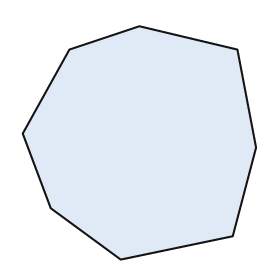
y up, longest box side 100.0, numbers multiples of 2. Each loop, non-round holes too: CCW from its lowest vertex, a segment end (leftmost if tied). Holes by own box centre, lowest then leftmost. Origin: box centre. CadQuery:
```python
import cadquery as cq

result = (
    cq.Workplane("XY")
    .moveTo(-8.0, -50.0)
    .lineTo(40.0, -40.0)
    .lineTo(50.0, -2.0)
    .lineTo(42.0, 40.0)
    .lineTo(0.0, 50.0)
    .lineTo(-30.0, 40.0)
    .lineTo(-50.0, 4.0)
    .lineTo(-38.0, -28.0)
    .close()
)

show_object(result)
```